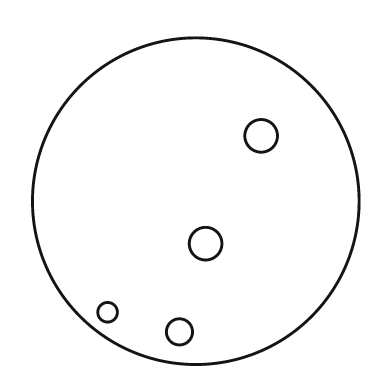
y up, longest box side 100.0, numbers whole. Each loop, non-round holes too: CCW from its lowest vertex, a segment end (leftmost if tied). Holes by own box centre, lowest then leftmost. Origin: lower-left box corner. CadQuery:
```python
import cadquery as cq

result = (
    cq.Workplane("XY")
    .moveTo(50.0, 50.0)
    .circle(50.0)
    .moveTo(45.0, 10.0)
    .circle(4.0)
    .moveTo(23.0, 16.0)
    .circle(3.0)
    .moveTo(53.0, 37.0)
    .circle(5.0)
    .moveTo(70.0, 70.0)
    .circle(5.0)
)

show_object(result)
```